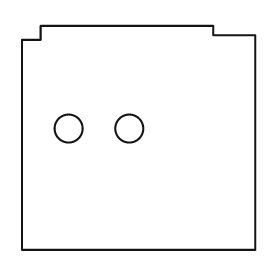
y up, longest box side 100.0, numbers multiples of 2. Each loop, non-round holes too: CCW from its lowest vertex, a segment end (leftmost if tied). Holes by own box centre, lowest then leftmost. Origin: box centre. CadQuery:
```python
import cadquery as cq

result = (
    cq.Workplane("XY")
    .moveTo(-50.0, -48.0)
    .lineTo(50.0, -48.0)
    .lineTo(50.0, 44.0)
    .lineTo(32.0, 44.0)
    .lineTo(32.0, 48.0)
    .lineTo(-42.0, 48.0)
    .lineTo(-42.0, 42.0)
    .lineTo(-50.0, 42.0)
    .close()
    .moveTo(-30.0, 4.0)
    .circle(6.0)
    .moveTo(-4.0, 4.0)
    .circle(6.0)
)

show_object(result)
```